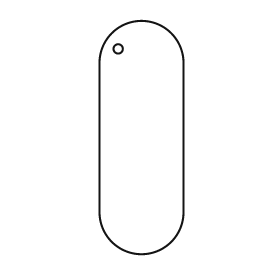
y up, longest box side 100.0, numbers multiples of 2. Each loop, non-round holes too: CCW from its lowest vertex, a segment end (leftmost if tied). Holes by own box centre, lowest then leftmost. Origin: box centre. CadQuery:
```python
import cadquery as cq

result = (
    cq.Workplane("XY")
    .moveTo(-18.0, -32.0)
    .threePointArc((0.0, -50.0), (18.0, -32.0))
    .lineTo(18.0, 32.0)
    .threePointArc((0.0, 50.0), (-18.0, 32.0))
    .close()
    .moveTo(-10.0, 38.0)
    .circle(2.0)
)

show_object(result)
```